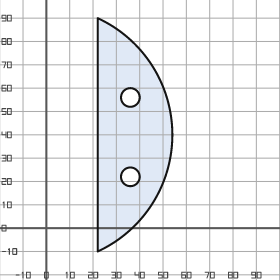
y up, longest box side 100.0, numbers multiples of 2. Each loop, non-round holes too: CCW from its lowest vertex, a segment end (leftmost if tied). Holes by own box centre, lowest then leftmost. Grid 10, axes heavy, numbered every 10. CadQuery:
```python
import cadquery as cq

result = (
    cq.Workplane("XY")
    .moveTo(22.0, -10.0)
    .threePointArc((54.0, 40.0), (22.0, 90.0))
    .close()
    .moveTo(36.0, 22.0)
    .circle(4.0)
    .moveTo(36.0, 56.0)
    .circle(4.0)
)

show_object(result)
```